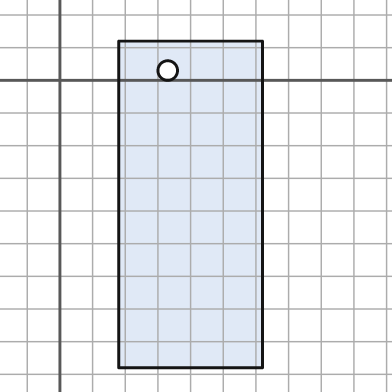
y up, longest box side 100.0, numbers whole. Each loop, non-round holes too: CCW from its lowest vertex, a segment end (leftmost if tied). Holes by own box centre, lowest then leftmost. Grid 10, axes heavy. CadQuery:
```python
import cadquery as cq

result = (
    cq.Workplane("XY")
    .moveTo(18.0, -88.0)
    .lineTo(62.0, -88.0)
    .lineTo(62.0, 12.0)
    .lineTo(18.0, 12.0)
    .close()
    .moveTo(33.0, 3.0)
    .circle(3.0)
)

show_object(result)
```